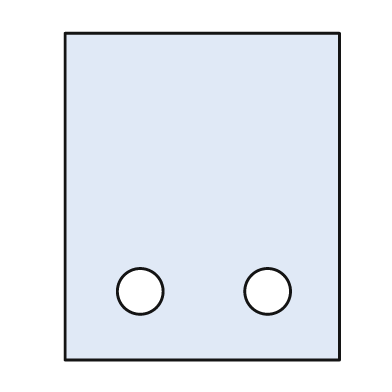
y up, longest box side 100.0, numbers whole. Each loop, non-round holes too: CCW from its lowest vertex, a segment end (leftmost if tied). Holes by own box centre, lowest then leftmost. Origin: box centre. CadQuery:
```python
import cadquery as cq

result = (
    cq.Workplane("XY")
    .moveTo(-42.0, -50.0)
    .lineTo(42.0, -50.0)
    .lineTo(42.0, 50.0)
    .lineTo(-42.0, 50.0)
    .close()
    .moveTo(-19.0, -29.0)
    .circle(7.0)
    .moveTo(20.0, -29.0)
    .circle(7.0)
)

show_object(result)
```